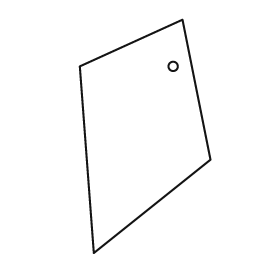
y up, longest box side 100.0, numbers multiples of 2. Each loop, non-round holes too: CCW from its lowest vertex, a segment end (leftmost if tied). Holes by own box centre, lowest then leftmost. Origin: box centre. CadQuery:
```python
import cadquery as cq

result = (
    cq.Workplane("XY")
    .moveTo(-22.0, -50.0)
    .lineTo(28.0, -10.0)
    .lineTo(16.0, 50.0)
    .lineTo(-28.0, 30.0)
    .close()
    .moveTo(12.0, 30.0)
    .circle(2.0)
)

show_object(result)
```